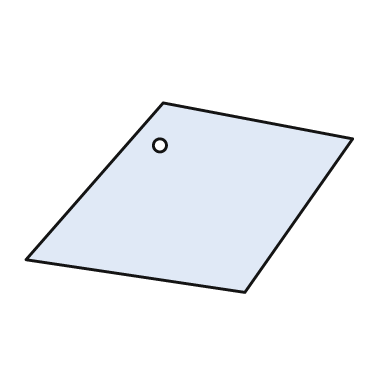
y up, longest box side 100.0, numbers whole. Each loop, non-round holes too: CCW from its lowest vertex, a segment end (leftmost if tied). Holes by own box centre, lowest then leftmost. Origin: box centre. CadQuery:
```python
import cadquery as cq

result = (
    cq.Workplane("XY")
    .moveTo(17.0, -29.0)
    .lineTo(50.0, 18.0)
    .lineTo(-8.0, 29.0)
    .lineTo(-50.0, -19.0)
    .close()
    .moveTo(-9.0, 16.0)
    .circle(2.0)
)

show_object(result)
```